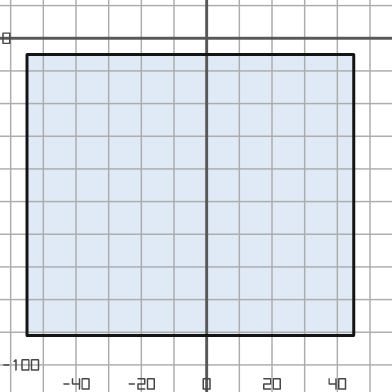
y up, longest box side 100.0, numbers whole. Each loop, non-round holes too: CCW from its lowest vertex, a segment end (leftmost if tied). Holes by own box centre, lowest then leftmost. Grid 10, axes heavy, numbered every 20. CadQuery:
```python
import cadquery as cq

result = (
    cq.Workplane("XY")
    .moveTo(-55.0, -91.0)
    .lineTo(45.0, -91.0)
    .lineTo(45.0, -5.0)
    .lineTo(-55.0, -5.0)
    .close()
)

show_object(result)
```